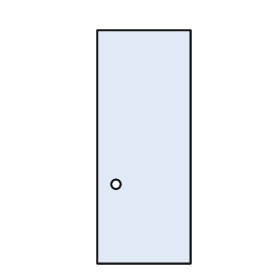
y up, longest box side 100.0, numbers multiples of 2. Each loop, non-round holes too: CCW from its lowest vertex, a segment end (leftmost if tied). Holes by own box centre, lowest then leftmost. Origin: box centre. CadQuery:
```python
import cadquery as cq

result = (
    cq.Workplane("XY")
    .moveTo(-20.0, -50.0)
    .lineTo(20.0, -50.0)
    .lineTo(20.0, 50.0)
    .lineTo(-20.0, 50.0)
    .close()
    .moveTo(-12.0, -16.0)
    .circle(2.0)
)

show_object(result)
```